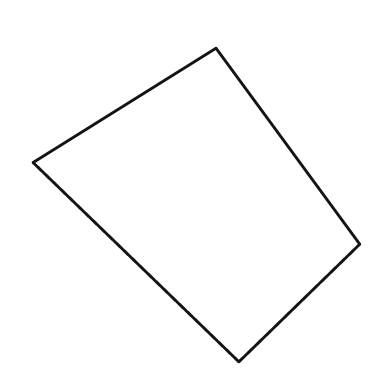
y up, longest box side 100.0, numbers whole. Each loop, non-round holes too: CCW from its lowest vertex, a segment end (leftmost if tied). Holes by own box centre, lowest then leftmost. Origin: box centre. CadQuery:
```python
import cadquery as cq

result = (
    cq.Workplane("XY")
    .moveTo(13.0, -48.0)
    .lineTo(50.0, -12.0)
    .lineTo(6.0, 48.0)
    .lineTo(-50.0, 13.0)
    .close()
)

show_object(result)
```